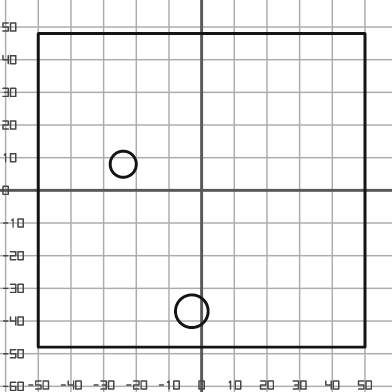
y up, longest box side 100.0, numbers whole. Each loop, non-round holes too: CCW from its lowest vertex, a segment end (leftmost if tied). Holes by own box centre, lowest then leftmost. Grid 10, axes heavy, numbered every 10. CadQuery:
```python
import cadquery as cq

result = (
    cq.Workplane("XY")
    .moveTo(-50.0, -48.0)
    .lineTo(50.0, -48.0)
    .lineTo(50.0, 48.0)
    .lineTo(-50.0, 48.0)
    .close()
    .moveTo(-3.0, -37.0)
    .circle(5.0)
    .moveTo(-24.0, 8.0)
    .circle(4.0)
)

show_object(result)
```